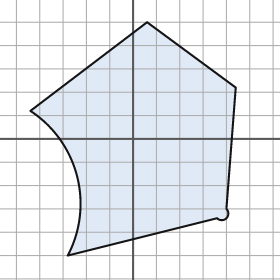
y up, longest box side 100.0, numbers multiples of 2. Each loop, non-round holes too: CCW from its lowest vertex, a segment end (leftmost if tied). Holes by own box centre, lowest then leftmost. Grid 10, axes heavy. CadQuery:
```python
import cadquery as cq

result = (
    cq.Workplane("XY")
    .moveTo(-28.0, -50.0)
    .lineTo(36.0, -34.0)
    .threePointArc((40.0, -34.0), (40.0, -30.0))
    .lineTo(44.0, 22.0)
    .lineTo(6.0, 50.0)
    .lineTo(-44.0, 12.0)
    .threePointArc((-24.0, -16.0), (-28.0, -50.0))
    .close()
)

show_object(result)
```